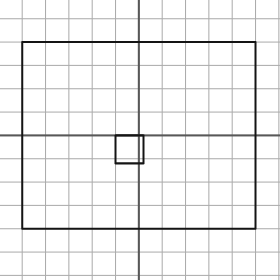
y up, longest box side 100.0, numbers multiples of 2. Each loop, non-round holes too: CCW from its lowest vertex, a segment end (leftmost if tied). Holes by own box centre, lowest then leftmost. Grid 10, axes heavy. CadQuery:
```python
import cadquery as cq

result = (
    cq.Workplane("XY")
    .moveTo(-50.0, -40.0)
    .lineTo(50.0, -40.0)
    .lineTo(50.0, 40.0)
    .lineTo(-50.0, 40.0)
    .close()
    .moveTo(-10.0, -12.0)
    .lineTo(2.0, -12.0)
    .lineTo(2.0, 0.0)
    .lineTo(-10.0, 0.0)
    .close()
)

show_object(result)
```